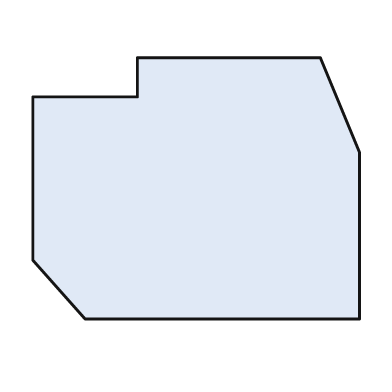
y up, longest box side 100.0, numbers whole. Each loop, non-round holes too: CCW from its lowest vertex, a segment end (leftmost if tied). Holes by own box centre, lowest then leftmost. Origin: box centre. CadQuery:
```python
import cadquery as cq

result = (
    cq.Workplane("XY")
    .moveTo(-34.0, -40.0)
    .lineTo(50.0, -40.0)
    .lineTo(50.0, 11.0)
    .lineTo(38.0, 40.0)
    .lineTo(-18.0, 40.0)
    .lineTo(-18.0, 28.0)
    .lineTo(-50.0, 28.0)
    .lineTo(-50.0, -22.0)
    .close()
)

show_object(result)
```